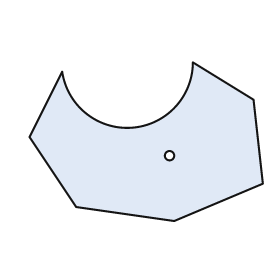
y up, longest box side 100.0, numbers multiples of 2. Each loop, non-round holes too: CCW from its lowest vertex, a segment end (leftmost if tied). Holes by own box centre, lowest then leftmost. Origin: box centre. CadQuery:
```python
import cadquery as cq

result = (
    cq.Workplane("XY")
    .moveTo(12.0, -34.0)
    .lineTo(50.0, -18.0)
    .lineTo(46.0, 18.0)
    .lineTo(20.0, 34.0)
    .threePointArc((-6.0, 6.0), (-36.0, 30.0))
    .lineTo(-50.0, 2.0)
    .lineTo(-30.0, -28.0)
    .close()
    .moveTo(10.0, -6.0)
    .circle(2.0)
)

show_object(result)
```